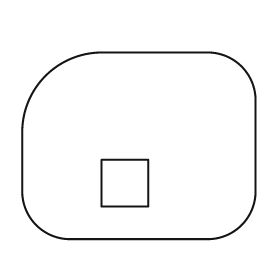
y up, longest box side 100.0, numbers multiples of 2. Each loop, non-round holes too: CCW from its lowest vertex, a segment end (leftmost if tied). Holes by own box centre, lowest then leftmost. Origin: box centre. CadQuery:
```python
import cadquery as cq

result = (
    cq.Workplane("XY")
    .moveTo(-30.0, -40.0)
    .lineTo(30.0, -40.0)
    .threePointArc((44.0, -34.0), (50.0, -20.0))
    .lineTo(50.0, 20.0)
    .threePointArc((44.0, 34.0), (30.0, 40.0))
    .lineTo(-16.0, 40.0)
    .threePointArc((-40.0, 30.0), (-50.0, 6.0))
    .lineTo(-50.0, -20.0)
    .threePointArc((-44.0, -34.0), (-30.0, -40.0))
    .close()
    .moveTo(-16.0, -26.0)
    .lineTo(4.0, -26.0)
    .lineTo(4.0, -6.0)
    .lineTo(-16.0, -6.0)
    .close()
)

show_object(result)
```